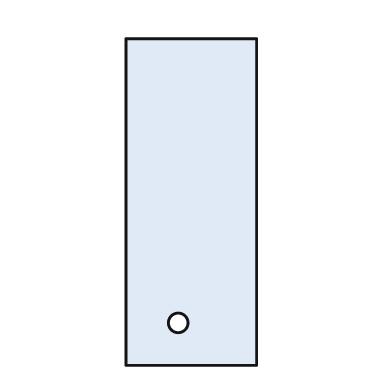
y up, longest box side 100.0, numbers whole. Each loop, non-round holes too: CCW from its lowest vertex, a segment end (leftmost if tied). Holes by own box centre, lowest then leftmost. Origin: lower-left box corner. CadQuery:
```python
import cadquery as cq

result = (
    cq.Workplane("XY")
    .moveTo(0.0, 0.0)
    .lineTo(40.0, 0.0)
    .lineTo(40.0, 100.0)
    .lineTo(0.0, 100.0)
    .close()
    .moveTo(16.0, 13.0)
    .circle(3.0)
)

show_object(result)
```